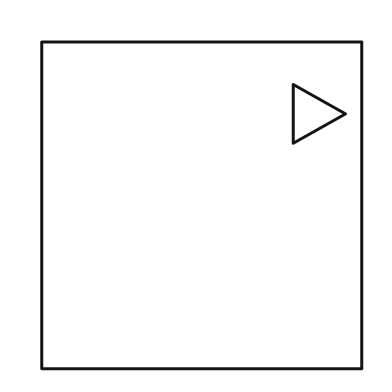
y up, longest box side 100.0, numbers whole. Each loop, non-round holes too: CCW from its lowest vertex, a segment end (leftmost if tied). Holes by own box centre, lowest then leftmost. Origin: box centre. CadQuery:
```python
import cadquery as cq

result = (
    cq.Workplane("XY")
    .moveTo(-49.0, -50.0)
    .lineTo(49.0, -50.0)
    .lineTo(49.0, 50.0)
    .lineTo(-49.0, 50.0)
    .close()
    .moveTo(28.0, 19.0)
    .lineTo(44.0, 28.0)
    .lineTo(28.0, 37.0)
    .close()
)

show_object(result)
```